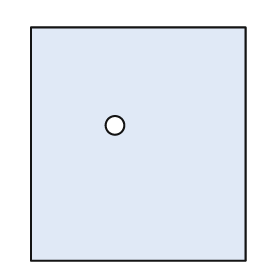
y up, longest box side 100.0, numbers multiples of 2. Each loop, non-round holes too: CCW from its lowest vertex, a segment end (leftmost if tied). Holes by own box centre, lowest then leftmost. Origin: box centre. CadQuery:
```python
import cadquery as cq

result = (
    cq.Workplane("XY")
    .moveTo(-46.0, -50.0)
    .lineTo(46.0, -50.0)
    .lineTo(46.0, 50.0)
    .lineTo(-46.0, 50.0)
    .close()
    .moveTo(-10.0, 8.0)
    .circle(4.0)
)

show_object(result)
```